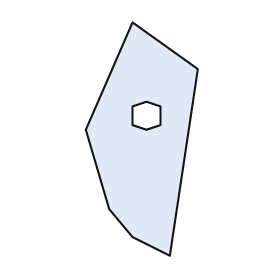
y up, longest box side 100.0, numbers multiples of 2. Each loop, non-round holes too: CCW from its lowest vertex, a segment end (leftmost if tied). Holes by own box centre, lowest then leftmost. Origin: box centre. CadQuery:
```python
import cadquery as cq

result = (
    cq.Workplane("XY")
    .moveTo(12.0, -50.0)
    .lineTo(24.0, 30.0)
    .lineTo(-4.0, 50.0)
    .lineTo(-24.0, 4.0)
    .lineTo(-14.0, -30.0)
    .lineTo(-4.0, -42.0)
    .close()
    .moveTo(2.0, 4.0)
    .lineTo(8.0, 6.0)
    .lineTo(8.0, 14.0)
    .lineTo(2.0, 16.0)
    .lineTo(-4.0, 14.0)
    .lineTo(-4.0, 6.0)
    .close()
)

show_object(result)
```